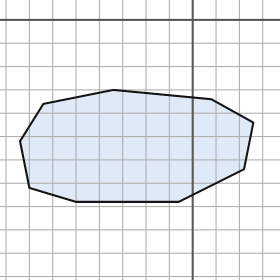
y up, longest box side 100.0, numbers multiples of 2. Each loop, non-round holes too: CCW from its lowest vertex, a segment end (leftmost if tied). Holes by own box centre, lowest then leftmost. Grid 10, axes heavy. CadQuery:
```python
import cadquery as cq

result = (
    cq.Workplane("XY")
    .moveTo(-50.0, -78.0)
    .lineTo(-6.0, -78.0)
    .lineTo(22.0, -64.0)
    .lineTo(26.0, -44.0)
    .lineTo(8.0, -34.0)
    .lineTo(-34.0, -30.0)
    .lineTo(-64.0, -36.0)
    .lineTo(-74.0, -52.0)
    .lineTo(-70.0, -72.0)
    .close()
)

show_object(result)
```